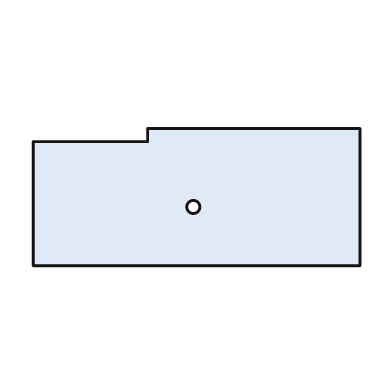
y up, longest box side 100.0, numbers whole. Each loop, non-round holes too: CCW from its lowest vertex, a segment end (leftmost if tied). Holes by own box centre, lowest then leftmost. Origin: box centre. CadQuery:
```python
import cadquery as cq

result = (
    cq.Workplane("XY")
    .moveTo(-50.0, -21.0)
    .lineTo(50.0, -21.0)
    .lineTo(50.0, 21.0)
    .lineTo(-15.0, 21.0)
    .lineTo(-15.0, 17.0)
    .lineTo(-50.0, 17.0)
    .close()
    .moveTo(-1.0, -3.0)
    .circle(2.0)
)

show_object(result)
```